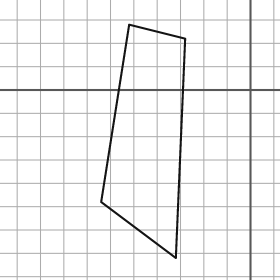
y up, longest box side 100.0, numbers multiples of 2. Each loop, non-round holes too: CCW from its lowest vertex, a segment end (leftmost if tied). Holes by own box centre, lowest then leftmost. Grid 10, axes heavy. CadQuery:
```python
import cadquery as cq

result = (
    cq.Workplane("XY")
    .moveTo(-32.0, -72.0)
    .lineTo(-28.0, 22.0)
    .lineTo(-52.0, 28.0)
    .lineTo(-64.0, -48.0)
    .close()
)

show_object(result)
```